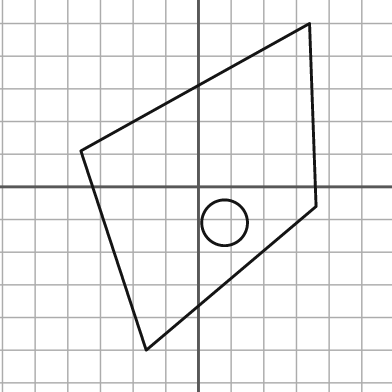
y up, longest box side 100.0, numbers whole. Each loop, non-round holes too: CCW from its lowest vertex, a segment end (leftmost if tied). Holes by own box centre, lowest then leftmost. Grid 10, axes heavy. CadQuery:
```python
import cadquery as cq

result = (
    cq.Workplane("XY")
    .moveTo(-16.0, -50.0)
    .lineTo(36.0, -6.0)
    .lineTo(34.0, 50.0)
    .lineTo(-36.0, 11.0)
    .close()
    .moveTo(8.0, -11.0)
    .circle(7.0)
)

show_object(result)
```